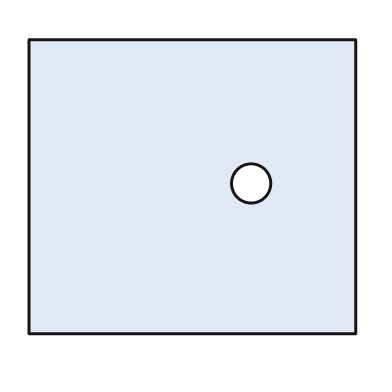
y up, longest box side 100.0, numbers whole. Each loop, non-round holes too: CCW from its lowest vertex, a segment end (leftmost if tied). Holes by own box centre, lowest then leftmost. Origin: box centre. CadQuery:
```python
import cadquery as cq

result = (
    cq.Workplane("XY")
    .moveTo(-50.0, -45.0)
    .lineTo(50.0, -45.0)
    .lineTo(50.0, 45.0)
    .lineTo(-50.0, 45.0)
    .close()
    .moveTo(18.0, 1.0)
    .circle(6.0)
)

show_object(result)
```